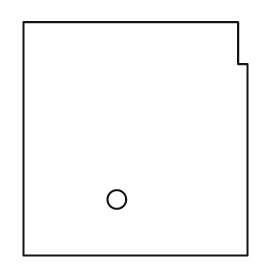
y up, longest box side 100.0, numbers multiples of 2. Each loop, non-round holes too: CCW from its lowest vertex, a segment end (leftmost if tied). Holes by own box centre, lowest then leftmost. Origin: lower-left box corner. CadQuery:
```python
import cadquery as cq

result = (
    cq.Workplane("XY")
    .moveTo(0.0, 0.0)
    .lineTo(96.0, 0.0)
    .lineTo(96.0, 82.0)
    .lineTo(92.0, 82.0)
    .lineTo(92.0, 100.0)
    .lineTo(0.0, 100.0)
    .close()
    .moveTo(40.0, 24.0)
    .circle(4.0)
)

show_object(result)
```